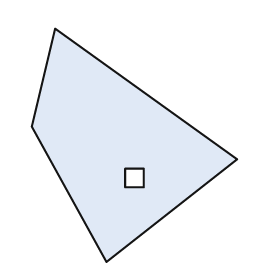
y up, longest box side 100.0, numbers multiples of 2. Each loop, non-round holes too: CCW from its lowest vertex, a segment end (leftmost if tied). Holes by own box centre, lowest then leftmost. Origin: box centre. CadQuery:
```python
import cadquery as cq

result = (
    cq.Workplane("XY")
    .moveTo(-12.0, -50.0)
    .lineTo(44.0, -6.0)
    .lineTo(-34.0, 50.0)
    .lineTo(-44.0, 8.0)
    .close()
    .moveTo(-4.0, -18.0)
    .lineTo(4.0, -18.0)
    .lineTo(4.0, -10.0)
    .lineTo(-4.0, -10.0)
    .close()
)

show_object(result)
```